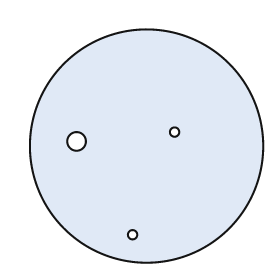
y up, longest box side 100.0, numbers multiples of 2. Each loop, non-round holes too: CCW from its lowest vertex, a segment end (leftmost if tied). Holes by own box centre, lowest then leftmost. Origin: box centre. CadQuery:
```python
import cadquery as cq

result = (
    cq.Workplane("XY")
    .moveTo(0.0, 0.0)
    .circle(50.0)
    .moveTo(-6.0, -38.0)
    .circle(2.0)
    .moveTo(-30.0, 2.0)
    .circle(4.0)
    .moveTo(12.0, 6.0)
    .circle(2.0)
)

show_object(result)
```